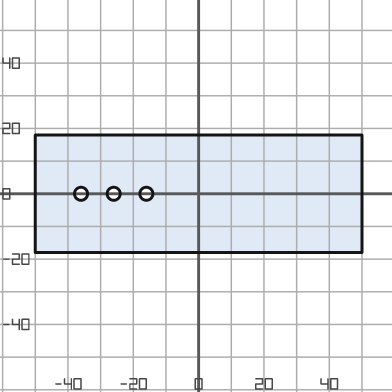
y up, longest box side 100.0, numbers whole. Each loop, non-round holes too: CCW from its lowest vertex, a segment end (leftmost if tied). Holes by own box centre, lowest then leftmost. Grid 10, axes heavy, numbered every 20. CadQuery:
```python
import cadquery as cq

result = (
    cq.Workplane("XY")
    .moveTo(-50.0, -18.0)
    .lineTo(50.0, -18.0)
    .lineTo(50.0, 18.0)
    .lineTo(-50.0, 18.0)
    .close()
    .moveTo(-36.0, 0.0)
    .circle(2.0)
    .moveTo(-26.0, 0.0)
    .circle(2.0)
    .moveTo(-16.0, 0.0)
    .circle(2.0)
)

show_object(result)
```